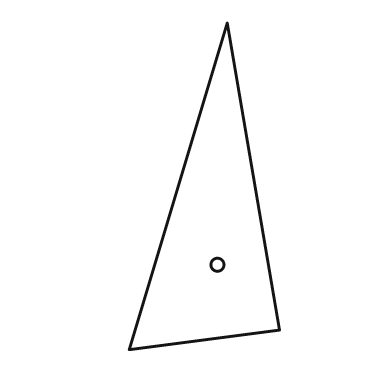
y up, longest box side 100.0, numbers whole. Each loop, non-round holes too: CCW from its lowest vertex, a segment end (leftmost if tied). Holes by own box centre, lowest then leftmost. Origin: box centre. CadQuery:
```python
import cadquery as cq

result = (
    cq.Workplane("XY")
    .moveTo(-23.0, -50.0)
    .lineTo(23.0, -44.0)
    .lineTo(7.0, 50.0)
    .close()
    .moveTo(4.0, -24.0)
    .circle(2.0)
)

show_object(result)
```